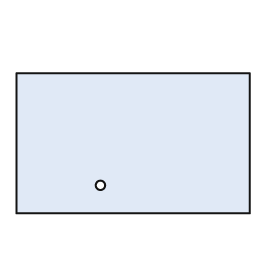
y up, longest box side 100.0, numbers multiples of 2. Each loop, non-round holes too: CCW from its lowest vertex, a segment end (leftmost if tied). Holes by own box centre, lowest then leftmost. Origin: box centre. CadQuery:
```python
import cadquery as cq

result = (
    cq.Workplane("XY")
    .moveTo(-50.0, -30.0)
    .lineTo(50.0, -30.0)
    .lineTo(50.0, 30.0)
    .lineTo(-50.0, 30.0)
    .close()
    .moveTo(-14.0, -18.0)
    .circle(2.0)
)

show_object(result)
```